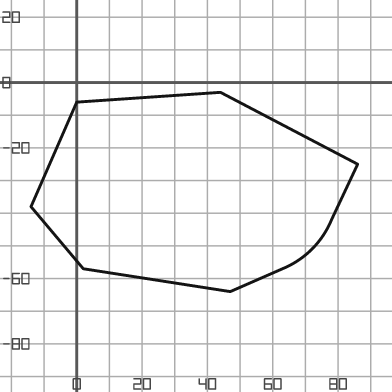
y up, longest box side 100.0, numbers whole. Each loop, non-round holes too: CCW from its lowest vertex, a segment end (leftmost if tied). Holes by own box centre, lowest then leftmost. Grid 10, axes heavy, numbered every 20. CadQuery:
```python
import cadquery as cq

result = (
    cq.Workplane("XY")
    .moveTo(47.0, -64.0)
    .lineTo(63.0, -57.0)
    .threePointArc((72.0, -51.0), (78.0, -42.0))
    .lineTo(86.0, -25.0)
    .lineTo(44.0, -3.0)
    .lineTo(0.0, -6.0)
    .lineTo(-14.0, -38.0)
    .lineTo(2.0, -57.0)
    .close()
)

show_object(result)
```